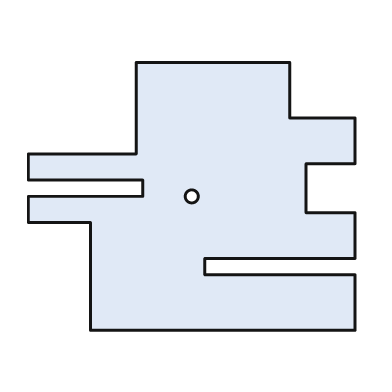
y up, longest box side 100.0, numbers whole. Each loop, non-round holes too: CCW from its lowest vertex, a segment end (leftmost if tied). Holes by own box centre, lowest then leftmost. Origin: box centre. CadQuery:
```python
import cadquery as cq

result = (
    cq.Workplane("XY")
    .moveTo(-31.0, -41.0)
    .lineTo(50.0, -41.0)
    .lineTo(50.0, -24.0)
    .lineTo(4.0, -24.0)
    .lineTo(4.0, -19.0)
    .lineTo(50.0, -19.0)
    .lineTo(50.0, -5.0)
    .lineTo(35.0, -5.0)
    .lineTo(35.0, 10.0)
    .lineTo(50.0, 10.0)
    .lineTo(50.0, 24.0)
    .lineTo(30.0, 24.0)
    .lineTo(30.0, 41.0)
    .lineTo(-17.0, 41.0)
    .lineTo(-17.0, 13.0)
    .lineTo(-50.0, 13.0)
    .lineTo(-50.0, 5.0)
    .lineTo(-15.0, 5.0)
    .lineTo(-15.0, 0.0)
    .lineTo(-50.0, 0.0)
    .lineTo(-50.0, -8.0)
    .lineTo(-31.0, -8.0)
    .close()
    .moveTo(0.0, 0.0)
    .circle(2.0)
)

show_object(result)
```